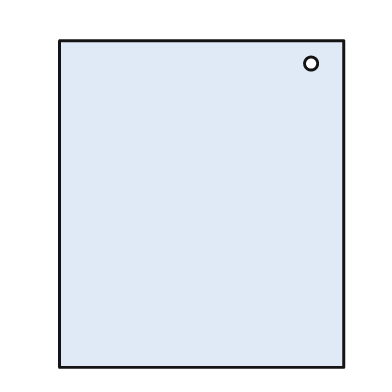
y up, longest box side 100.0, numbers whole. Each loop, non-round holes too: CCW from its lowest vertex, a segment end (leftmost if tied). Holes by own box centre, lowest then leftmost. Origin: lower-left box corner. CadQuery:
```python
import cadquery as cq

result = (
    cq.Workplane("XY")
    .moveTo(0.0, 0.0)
    .lineTo(87.0, 0.0)
    .lineTo(87.0, 100.0)
    .lineTo(0.0, 100.0)
    .close()
    .moveTo(77.0, 93.0)
    .circle(2.0)
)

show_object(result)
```